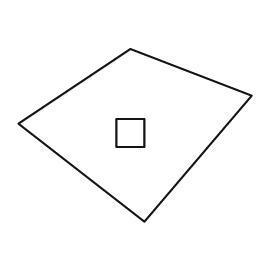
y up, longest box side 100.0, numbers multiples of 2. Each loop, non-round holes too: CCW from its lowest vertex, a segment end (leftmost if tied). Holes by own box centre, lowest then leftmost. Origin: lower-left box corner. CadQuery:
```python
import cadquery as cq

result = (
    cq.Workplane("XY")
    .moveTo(54.0, 0.0)
    .lineTo(100.0, 54.0)
    .lineTo(48.0, 74.0)
    .lineTo(0.0, 42.0)
    .close()
    .moveTo(42.0, 32.0)
    .lineTo(54.0, 32.0)
    .lineTo(54.0, 44.0)
    .lineTo(42.0, 44.0)
    .close()
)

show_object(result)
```